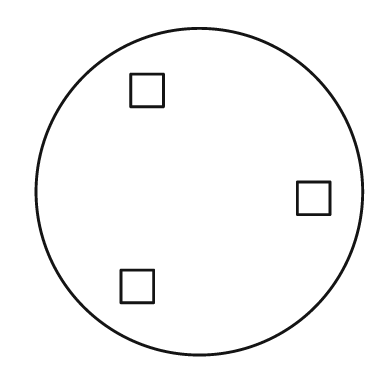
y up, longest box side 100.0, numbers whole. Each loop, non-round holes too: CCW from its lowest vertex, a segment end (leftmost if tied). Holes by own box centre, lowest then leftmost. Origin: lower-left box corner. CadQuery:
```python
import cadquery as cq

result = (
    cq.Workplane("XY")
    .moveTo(50.0, 50.0)
    .circle(50.0)
    .moveTo(26.0, 16.0)
    .lineTo(36.0, 16.0)
    .lineTo(36.0, 26.0)
    .lineTo(26.0, 26.0)
    .close()
    .moveTo(80.0, 43.0)
    .lineTo(90.0, 43.0)
    .lineTo(90.0, 53.0)
    .lineTo(80.0, 53.0)
    .close()
    .moveTo(29.0, 76.0)
    .lineTo(39.0, 76.0)
    .lineTo(39.0, 86.0)
    .lineTo(29.0, 86.0)
    .close()
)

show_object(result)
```